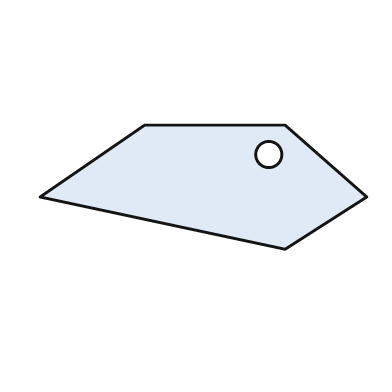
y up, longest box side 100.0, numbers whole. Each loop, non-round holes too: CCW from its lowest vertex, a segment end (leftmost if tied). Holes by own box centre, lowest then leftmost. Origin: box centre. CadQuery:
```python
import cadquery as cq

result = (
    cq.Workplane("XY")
    .moveTo(25.0, -19.0)
    .lineTo(50.0, -3.0)
    .lineTo(25.0, 19.0)
    .lineTo(-18.0, 19.0)
    .lineTo(-50.0, -3.0)
    .close()
    .moveTo(20.0, 10.0)
    .circle(4.0)
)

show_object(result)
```